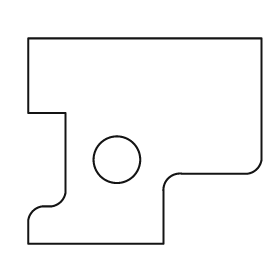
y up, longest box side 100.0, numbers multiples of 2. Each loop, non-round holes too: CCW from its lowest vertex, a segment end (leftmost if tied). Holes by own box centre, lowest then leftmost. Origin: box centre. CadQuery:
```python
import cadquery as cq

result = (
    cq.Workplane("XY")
    .moveTo(-50.0, -44.0)
    .lineTo(8.0, -44.0)
    .lineTo(8.0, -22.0)
    .threePointArc((10.0, -16.0), (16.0, -14.0))
    .lineTo(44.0, -14.0)
    .threePointArc((48.0, -12.0), (50.0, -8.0))
    .lineTo(50.0, 44.0)
    .lineTo(-50.0, 44.0)
    .lineTo(-50.0, 12.0)
    .lineTo(-34.0, 12.0)
    .lineTo(-34.0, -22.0)
    .threePointArc((-36.0, -26.0), (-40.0, -28.0))
    .lineTo(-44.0, -28.0)
    .threePointArc((-48.0, -30.0), (-50.0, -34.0))
    .close()
    .moveTo(-12.0, -8.0)
    .circle(10.0)
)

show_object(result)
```